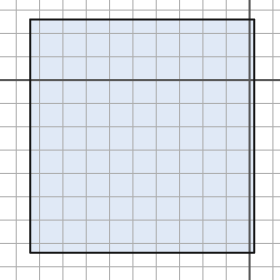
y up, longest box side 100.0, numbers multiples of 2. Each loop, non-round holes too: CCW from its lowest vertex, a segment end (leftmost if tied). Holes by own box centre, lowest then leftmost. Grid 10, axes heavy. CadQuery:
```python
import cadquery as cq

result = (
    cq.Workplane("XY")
    .moveTo(-94.0, -74.0)
    .lineTo(2.0, -74.0)
    .lineTo(2.0, 26.0)
    .lineTo(-94.0, 26.0)
    .close()
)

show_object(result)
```